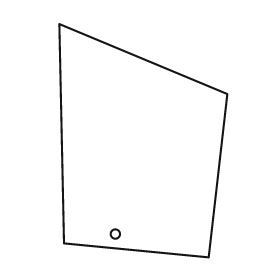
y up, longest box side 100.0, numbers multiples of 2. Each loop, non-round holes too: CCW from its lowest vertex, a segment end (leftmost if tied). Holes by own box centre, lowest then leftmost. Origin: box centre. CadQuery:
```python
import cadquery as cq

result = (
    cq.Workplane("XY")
    .moveTo(28.0, -50.0)
    .lineTo(36.0, 20.0)
    .lineTo(-36.0, 50.0)
    .lineTo(-34.0, -44.0)
    .close()
    .moveTo(-12.0, -40.0)
    .circle(2.0)
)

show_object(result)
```